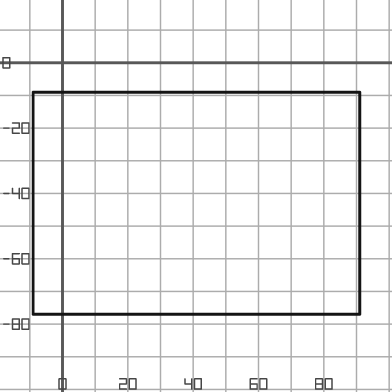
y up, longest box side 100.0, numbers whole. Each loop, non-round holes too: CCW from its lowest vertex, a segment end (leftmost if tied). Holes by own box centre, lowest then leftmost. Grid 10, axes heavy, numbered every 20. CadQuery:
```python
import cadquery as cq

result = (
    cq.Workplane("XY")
    .moveTo(-9.0, -77.0)
    .lineTo(91.0, -77.0)
    .lineTo(91.0, -9.0)
    .lineTo(-9.0, -9.0)
    .close()
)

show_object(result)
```